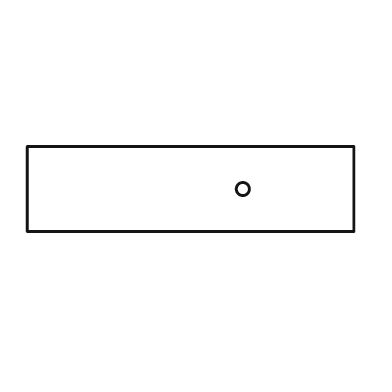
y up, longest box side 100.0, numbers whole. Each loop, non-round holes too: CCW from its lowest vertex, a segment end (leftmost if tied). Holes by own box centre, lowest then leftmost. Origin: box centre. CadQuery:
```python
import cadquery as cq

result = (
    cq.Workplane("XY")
    .moveTo(-50.0, -13.0)
    .lineTo(50.0, -13.0)
    .lineTo(50.0, 13.0)
    .lineTo(-50.0, 13.0)
    .close()
    .moveTo(16.0, 0.0)
    .circle(2.0)
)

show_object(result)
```